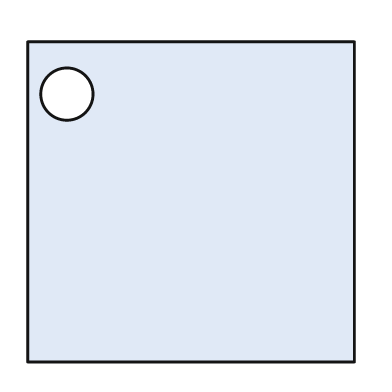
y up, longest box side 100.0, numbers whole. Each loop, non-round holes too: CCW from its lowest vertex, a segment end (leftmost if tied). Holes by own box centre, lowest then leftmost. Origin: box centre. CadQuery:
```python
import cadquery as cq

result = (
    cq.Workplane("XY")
    .moveTo(-50.0, -49.0)
    .lineTo(50.0, -49.0)
    .lineTo(50.0, 49.0)
    .lineTo(-50.0, 49.0)
    .close()
    .moveTo(-38.0, 33.0)
    .circle(8.0)
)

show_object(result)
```